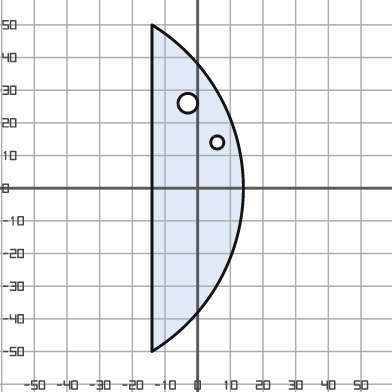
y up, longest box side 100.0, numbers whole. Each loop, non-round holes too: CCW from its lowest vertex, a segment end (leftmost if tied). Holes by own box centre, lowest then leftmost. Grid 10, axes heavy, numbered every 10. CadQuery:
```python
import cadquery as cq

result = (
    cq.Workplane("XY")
    .moveTo(-14.0, -50.0)
    .threePointArc((14.0, 0.0), (-14.0, 50.0))
    .close()
    .moveTo(6.0, 14.0)
    .circle(2.0)
    .moveTo(-3.0, 26.0)
    .circle(3.0)
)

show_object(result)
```